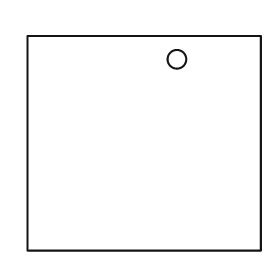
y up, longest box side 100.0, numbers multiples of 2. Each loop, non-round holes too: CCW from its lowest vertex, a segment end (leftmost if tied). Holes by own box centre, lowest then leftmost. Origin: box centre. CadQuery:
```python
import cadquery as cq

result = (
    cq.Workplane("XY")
    .moveTo(-50.0, -46.0)
    .lineTo(50.0, -46.0)
    .lineTo(50.0, 46.0)
    .lineTo(-50.0, 46.0)
    .close()
    .moveTo(14.0, 36.0)
    .circle(4.0)
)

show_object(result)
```